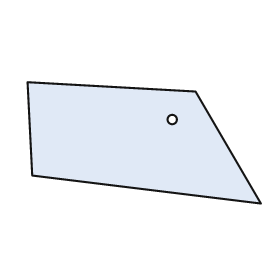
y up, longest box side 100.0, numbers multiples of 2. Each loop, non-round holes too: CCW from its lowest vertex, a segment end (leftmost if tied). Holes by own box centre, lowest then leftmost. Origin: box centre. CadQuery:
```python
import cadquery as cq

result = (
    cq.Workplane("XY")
    .moveTo(50.0, -26.0)
    .lineTo(22.0, 22.0)
    .lineTo(-50.0, 26.0)
    .lineTo(-48.0, -14.0)
    .close()
    .moveTo(12.0, 10.0)
    .circle(2.0)
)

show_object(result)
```